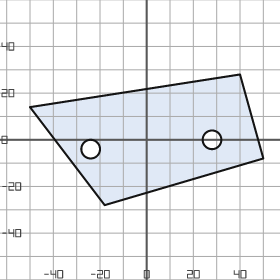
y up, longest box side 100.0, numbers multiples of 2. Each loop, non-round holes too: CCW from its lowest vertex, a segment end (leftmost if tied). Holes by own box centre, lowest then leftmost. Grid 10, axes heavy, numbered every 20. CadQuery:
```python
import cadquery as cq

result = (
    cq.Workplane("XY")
    .moveTo(-18.0, -28.0)
    .lineTo(50.0, -8.0)
    .lineTo(40.0, 28.0)
    .lineTo(-50.0, 14.0)
    .close()
    .moveTo(-24.0, -4.0)
    .circle(4.0)
    .moveTo(28.0, 0.0)
    .circle(4.0)
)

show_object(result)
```